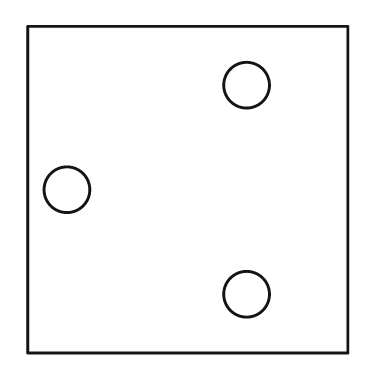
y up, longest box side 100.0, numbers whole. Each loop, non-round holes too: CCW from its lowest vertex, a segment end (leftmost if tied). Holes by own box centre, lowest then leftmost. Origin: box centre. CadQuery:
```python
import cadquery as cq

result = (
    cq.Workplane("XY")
    .moveTo(-49.0, -50.0)
    .lineTo(49.0, -50.0)
    .lineTo(49.0, 50.0)
    .lineTo(-49.0, 50.0)
    .close()
    .moveTo(18.0, -32.0)
    .circle(7.0)
    .moveTo(-37.0, 0.0)
    .circle(7.0)
    .moveTo(18.0, 32.0)
    .circle(7.0)
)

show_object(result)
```